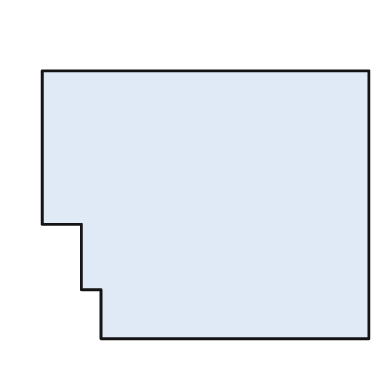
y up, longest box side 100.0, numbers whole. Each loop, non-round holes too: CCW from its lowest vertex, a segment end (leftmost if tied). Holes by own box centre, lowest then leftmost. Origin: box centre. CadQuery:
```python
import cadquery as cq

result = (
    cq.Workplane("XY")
    .moveTo(-32.0, -41.0)
    .lineTo(50.0, -41.0)
    .lineTo(50.0, 41.0)
    .lineTo(-50.0, 41.0)
    .lineTo(-50.0, -6.0)
    .lineTo(-38.0, -6.0)
    .lineTo(-38.0, -26.0)
    .lineTo(-32.0, -26.0)
    .close()
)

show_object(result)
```